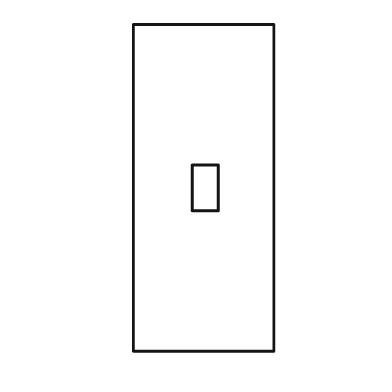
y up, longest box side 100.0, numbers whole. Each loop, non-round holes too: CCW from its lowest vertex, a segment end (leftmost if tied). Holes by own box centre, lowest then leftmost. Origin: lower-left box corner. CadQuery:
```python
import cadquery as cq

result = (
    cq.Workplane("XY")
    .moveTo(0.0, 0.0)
    .lineTo(43.0, 0.0)
    .lineTo(43.0, 100.0)
    .lineTo(0.0, 100.0)
    .close()
    .moveTo(18.0, 43.0)
    .lineTo(26.0, 43.0)
    .lineTo(26.0, 57.0)
    .lineTo(18.0, 57.0)
    .close()
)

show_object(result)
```